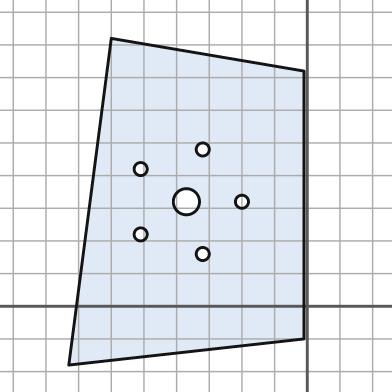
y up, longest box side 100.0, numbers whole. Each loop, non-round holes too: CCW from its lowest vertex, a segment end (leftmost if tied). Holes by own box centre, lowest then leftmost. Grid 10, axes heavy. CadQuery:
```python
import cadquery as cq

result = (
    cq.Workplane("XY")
    .moveTo(-73.0, -18.0)
    .lineTo(-1.0, -10.0)
    .lineTo(-1.0, 72.0)
    .lineTo(-60.0, 82.0)
    .close()
    .moveTo(-32.0, 16.0)
    .circle(2.0)
    .moveTo(-51.0, 22.0)
    .circle(2.0)
    .moveTo(-37.0, 32.0)
    .circle(4.0)
    .moveTo(-20.0, 32.0)
    .circle(2.0)
    .moveTo(-51.0, 42.0)
    .circle(2.0)
    .moveTo(-32.0, 48.0)
    .circle(2.0)
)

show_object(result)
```